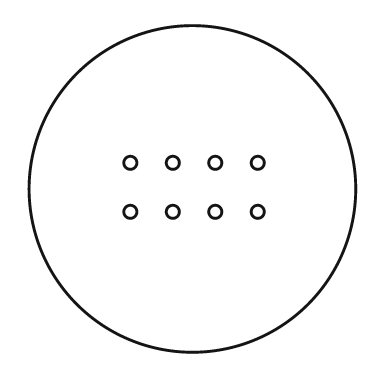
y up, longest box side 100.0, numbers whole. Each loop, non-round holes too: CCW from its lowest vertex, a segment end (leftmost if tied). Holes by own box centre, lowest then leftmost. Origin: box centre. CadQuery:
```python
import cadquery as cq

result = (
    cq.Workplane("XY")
    .moveTo(0.0, 0.0)
    .circle(50.0)
    .moveTo(-19.0, -7.0)
    .circle(2.0)
    .moveTo(-6.0, -7.0)
    .circle(2.0)
    .moveTo(7.0, -7.0)
    .circle(2.0)
    .moveTo(20.0, -7.0)
    .circle(2.0)
    .moveTo(-19.0, 8.0)
    .circle(2.0)
    .moveTo(-6.0, 8.0)
    .circle(2.0)
    .moveTo(7.0, 8.0)
    .circle(2.0)
    .moveTo(20.0, 8.0)
    .circle(2.0)
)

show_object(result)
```